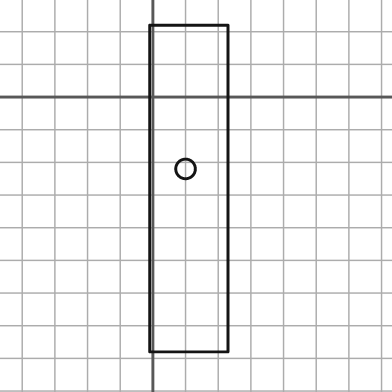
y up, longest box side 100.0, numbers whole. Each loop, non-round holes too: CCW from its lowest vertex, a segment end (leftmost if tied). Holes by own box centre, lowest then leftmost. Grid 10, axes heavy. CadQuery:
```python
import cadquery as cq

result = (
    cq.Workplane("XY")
    .moveTo(-1.0, -78.0)
    .lineTo(23.0, -78.0)
    .lineTo(23.0, 22.0)
    .lineTo(-1.0, 22.0)
    .close()
    .moveTo(10.0, -22.0)
    .circle(3.0)
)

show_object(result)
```